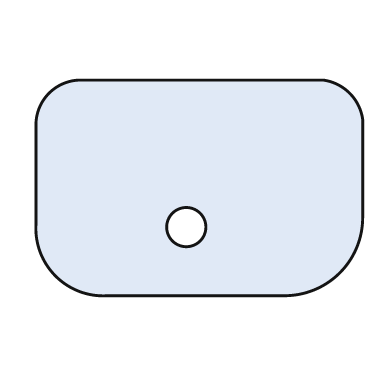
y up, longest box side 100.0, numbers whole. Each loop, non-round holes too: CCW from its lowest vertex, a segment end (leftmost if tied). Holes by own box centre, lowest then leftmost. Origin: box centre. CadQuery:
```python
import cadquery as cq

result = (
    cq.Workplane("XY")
    .moveTo(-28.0, -33.0)
    .lineTo(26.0, -33.0)
    .threePointArc((43.0, -26.0), (50.0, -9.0))
    .lineTo(50.0, 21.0)
    .threePointArc((46.0, 29.0), (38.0, 33.0))
    .lineTo(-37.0, 33.0)
    .threePointArc((-46.0, 29.0), (-50.0, 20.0))
    .lineTo(-50.0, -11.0)
    .threePointArc((-44.0, -27.0), (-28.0, -33.0))
    .close()
    .moveTo(-4.0, -12.0)
    .circle(6.0)
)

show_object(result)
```